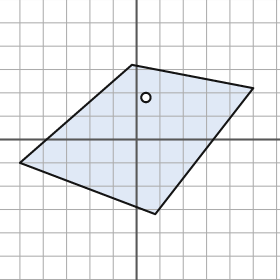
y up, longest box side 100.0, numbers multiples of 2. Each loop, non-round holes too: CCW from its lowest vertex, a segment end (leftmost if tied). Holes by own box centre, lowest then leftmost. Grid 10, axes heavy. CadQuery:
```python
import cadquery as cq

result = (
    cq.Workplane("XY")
    .moveTo(8.0, -32.0)
    .lineTo(50.0, 22.0)
    .lineTo(-2.0, 32.0)
    .lineTo(-50.0, -10.0)
    .close()
    .moveTo(4.0, 18.0)
    .circle(2.0)
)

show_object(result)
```